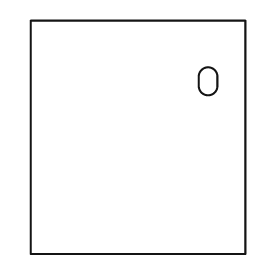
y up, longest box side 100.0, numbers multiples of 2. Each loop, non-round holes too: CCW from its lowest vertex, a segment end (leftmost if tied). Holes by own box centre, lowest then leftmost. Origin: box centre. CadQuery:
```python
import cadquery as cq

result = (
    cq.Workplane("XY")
    .moveTo(-46.0, -50.0)
    .lineTo(46.0, -50.0)
    .lineTo(46.0, 50.0)
    .lineTo(-46.0, 50.0)
    .close()
    .moveTo(26.0, 22.0)
    .threePointArc((30.0, 18.0), (34.0, 22.0))
    .lineTo(34.0, 26.0)
    .threePointArc((30.0, 30.0), (26.0, 26.0))
    .close()
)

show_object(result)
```